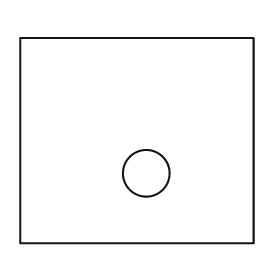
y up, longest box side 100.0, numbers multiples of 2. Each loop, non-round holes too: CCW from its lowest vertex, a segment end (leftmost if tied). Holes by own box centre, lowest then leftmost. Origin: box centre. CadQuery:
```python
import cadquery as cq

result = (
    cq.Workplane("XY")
    .moveTo(-50.0, -44.0)
    .lineTo(50.0, -44.0)
    .lineTo(50.0, 44.0)
    .lineTo(-50.0, 44.0)
    .close()
    .moveTo(4.0, -14.0)
    .circle(10.0)
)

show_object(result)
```